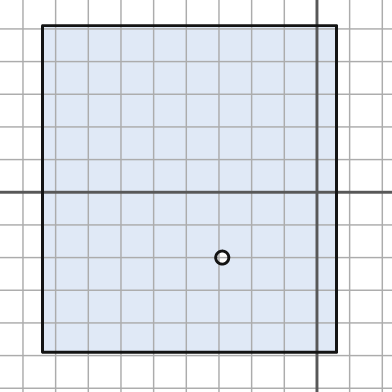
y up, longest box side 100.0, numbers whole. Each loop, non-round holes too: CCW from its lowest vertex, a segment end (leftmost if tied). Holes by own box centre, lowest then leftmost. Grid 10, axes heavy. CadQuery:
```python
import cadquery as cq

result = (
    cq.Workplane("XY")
    .moveTo(-84.0, -49.0)
    .lineTo(6.0, -49.0)
    .lineTo(6.0, 51.0)
    .lineTo(-84.0, 51.0)
    .close()
    .moveTo(-29.0, -20.0)
    .circle(2.0)
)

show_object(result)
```